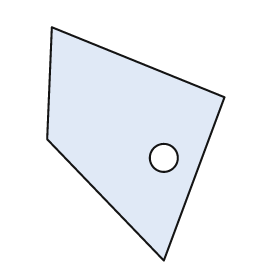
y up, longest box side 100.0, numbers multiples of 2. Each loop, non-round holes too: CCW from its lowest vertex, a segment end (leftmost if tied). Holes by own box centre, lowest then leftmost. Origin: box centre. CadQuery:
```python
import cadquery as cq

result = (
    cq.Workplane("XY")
    .moveTo(12.0, -50.0)
    .lineTo(38.0, 20.0)
    .lineTo(-36.0, 50.0)
    .lineTo(-38.0, 2.0)
    .close()
    .moveTo(12.0, -6.0)
    .circle(6.0)
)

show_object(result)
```